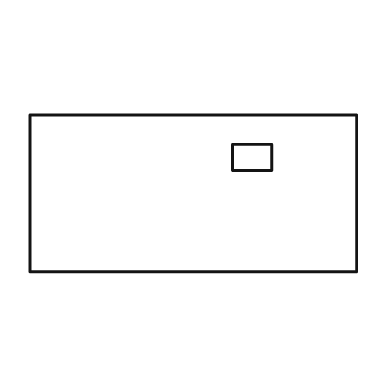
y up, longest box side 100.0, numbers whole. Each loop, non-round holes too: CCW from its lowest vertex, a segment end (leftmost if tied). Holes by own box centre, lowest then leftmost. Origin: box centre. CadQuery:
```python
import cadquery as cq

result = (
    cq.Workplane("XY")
    .moveTo(-50.0, -24.0)
    .lineTo(50.0, -24.0)
    .lineTo(50.0, 24.0)
    .lineTo(-50.0, 24.0)
    .close()
    .moveTo(12.0, 7.0)
    .lineTo(24.0, 7.0)
    .lineTo(24.0, 15.0)
    .lineTo(12.0, 15.0)
    .close()
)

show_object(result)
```